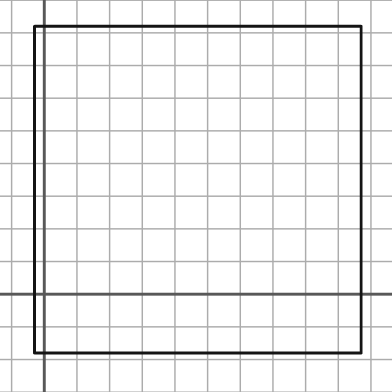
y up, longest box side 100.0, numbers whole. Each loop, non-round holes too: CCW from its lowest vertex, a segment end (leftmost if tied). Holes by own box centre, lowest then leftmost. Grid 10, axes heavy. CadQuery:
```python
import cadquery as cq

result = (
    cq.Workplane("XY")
    .moveTo(-3.0, -18.0)
    .lineTo(97.0, -18.0)
    .lineTo(97.0, 82.0)
    .lineTo(-3.0, 82.0)
    .close()
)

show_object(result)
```